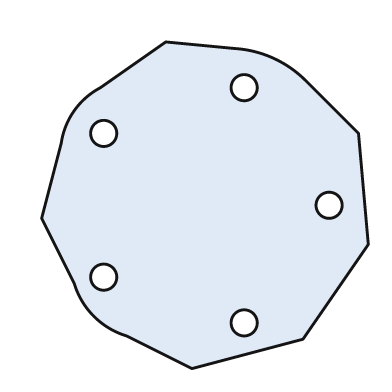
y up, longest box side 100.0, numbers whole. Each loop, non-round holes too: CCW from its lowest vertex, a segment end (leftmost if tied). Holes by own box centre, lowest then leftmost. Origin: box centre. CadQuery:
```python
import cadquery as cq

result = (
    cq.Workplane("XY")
    .moveTo(-4.0, -50.0)
    .lineTo(30.0, -41.0)
    .lineTo(50.0, -12.0)
    .lineTo(47.0, 22.0)
    .lineTo(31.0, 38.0)
    .threePointArc((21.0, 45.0), (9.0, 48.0))
    .lineTo(-12.0, 50.0)
    .lineTo(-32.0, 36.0)
    .threePointArc((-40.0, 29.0), (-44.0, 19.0))
    .lineTo(-50.0, -4.0)
    .lineTo(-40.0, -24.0)
    .threePointArc((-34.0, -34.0), (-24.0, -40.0))
    .close()
    .moveTo(12.0, -36.0)
    .circle(4.0)
    .moveTo(-31.0, -22.0)
    .circle(4.0)
    .moveTo(38.0, 0.0)
    .circle(4.0)
    .moveTo(-31.0, 22.0)
    .circle(4.0)
    .moveTo(12.0, 36.0)
    .circle(4.0)
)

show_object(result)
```